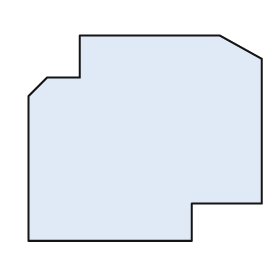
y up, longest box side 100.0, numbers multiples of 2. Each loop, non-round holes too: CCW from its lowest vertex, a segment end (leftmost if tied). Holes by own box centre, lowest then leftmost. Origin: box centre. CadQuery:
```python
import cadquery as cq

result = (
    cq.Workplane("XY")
    .moveTo(-50.0, -44.0)
    .lineTo(20.0, -44.0)
    .lineTo(20.0, -28.0)
    .lineTo(50.0, -28.0)
    .lineTo(50.0, 34.0)
    .lineTo(32.0, 44.0)
    .lineTo(-28.0, 44.0)
    .lineTo(-28.0, 26.0)
    .lineTo(-42.0, 26.0)
    .lineTo(-50.0, 18.0)
    .close()
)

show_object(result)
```